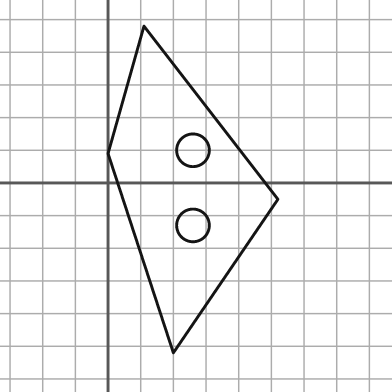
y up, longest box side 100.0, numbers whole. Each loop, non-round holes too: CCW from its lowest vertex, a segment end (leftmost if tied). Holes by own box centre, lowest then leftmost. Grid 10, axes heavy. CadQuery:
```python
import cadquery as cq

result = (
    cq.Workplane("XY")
    .moveTo(20.0, -52.0)
    .lineTo(52.0, -5.0)
    .lineTo(11.0, 48.0)
    .lineTo(0.0, 9.0)
    .close()
    .moveTo(26.0, -13.0)
    .circle(5.0)
    .moveTo(26.0, 10.0)
    .circle(5.0)
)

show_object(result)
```